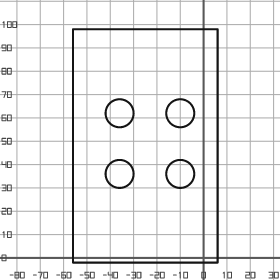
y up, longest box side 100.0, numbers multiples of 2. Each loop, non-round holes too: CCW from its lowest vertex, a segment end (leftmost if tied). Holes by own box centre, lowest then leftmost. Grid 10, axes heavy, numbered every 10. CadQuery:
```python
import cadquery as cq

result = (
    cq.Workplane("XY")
    .moveTo(-56.0, -2.0)
    .lineTo(6.0, -2.0)
    .lineTo(6.0, 98.0)
    .lineTo(-56.0, 98.0)
    .close()
    .moveTo(-36.0, 36.0)
    .circle(6.0)
    .moveTo(-10.0, 36.0)
    .circle(6.0)
    .moveTo(-36.0, 62.0)
    .circle(6.0)
    .moveTo(-10.0, 62.0)
    .circle(6.0)
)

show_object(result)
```